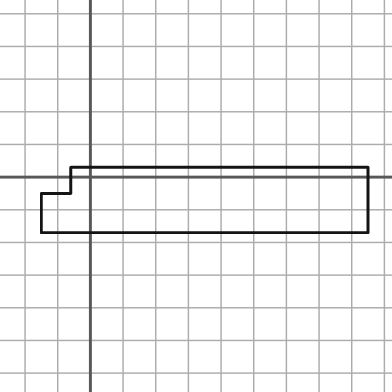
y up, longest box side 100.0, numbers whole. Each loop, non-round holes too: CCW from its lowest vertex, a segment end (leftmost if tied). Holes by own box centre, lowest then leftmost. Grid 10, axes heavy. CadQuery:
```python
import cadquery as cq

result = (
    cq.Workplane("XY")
    .moveTo(-15.0, -17.0)
    .lineTo(85.0, -17.0)
    .lineTo(85.0, 3.0)
    .lineTo(-6.0, 3.0)
    .lineTo(-6.0, -5.0)
    .lineTo(-15.0, -5.0)
    .close()
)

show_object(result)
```